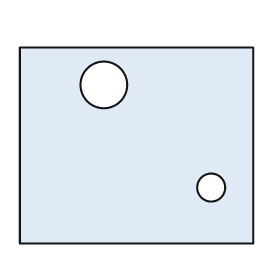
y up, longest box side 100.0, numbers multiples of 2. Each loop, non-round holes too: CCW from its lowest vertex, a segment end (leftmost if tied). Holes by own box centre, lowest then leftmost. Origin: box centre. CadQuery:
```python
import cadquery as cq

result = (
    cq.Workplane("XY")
    .moveTo(-50.0, -42.0)
    .lineTo(50.0, -42.0)
    .lineTo(50.0, 42.0)
    .lineTo(-50.0, 42.0)
    .close()
    .moveTo(32.0, -18.0)
    .circle(6.0)
    .moveTo(-14.0, 26.0)
    .circle(10.0)
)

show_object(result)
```